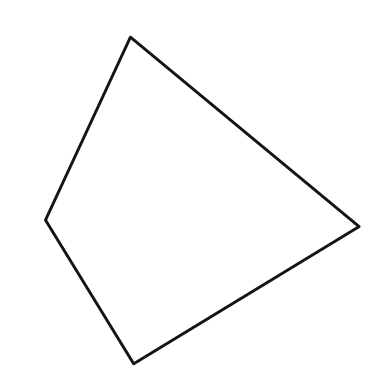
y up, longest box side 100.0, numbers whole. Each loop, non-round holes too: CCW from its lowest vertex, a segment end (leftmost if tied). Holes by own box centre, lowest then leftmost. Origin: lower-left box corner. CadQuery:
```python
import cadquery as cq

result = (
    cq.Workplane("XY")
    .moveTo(27.0, 0.0)
    .lineTo(96.0, 42.0)
    .lineTo(26.0, 100.0)
    .lineTo(0.0, 44.0)
    .close()
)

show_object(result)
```